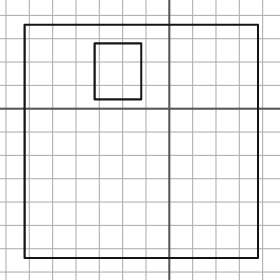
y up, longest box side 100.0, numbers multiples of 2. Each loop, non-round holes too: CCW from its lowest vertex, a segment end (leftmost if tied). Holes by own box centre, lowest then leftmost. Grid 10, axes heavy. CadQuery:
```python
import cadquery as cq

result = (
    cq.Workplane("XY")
    .moveTo(-62.0, -64.0)
    .lineTo(38.0, -64.0)
    .lineTo(38.0, 36.0)
    .lineTo(-62.0, 36.0)
    .close()
    .moveTo(-32.0, 4.0)
    .lineTo(-12.0, 4.0)
    .lineTo(-12.0, 28.0)
    .lineTo(-32.0, 28.0)
    .close()
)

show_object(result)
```